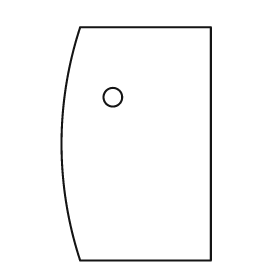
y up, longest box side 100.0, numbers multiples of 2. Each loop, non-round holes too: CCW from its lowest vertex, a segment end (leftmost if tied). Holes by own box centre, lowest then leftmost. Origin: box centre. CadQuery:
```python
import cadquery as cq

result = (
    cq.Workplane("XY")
    .moveTo(-24.0, -50.0)
    .lineTo(32.0, -50.0)
    .lineTo(32.0, 50.0)
    .lineTo(-24.0, 50.0)
    .threePointArc((-32.0, 0.0), (-24.0, -50.0))
    .close()
    .moveTo(-10.0, 20.0)
    .circle(4.0)
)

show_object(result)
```